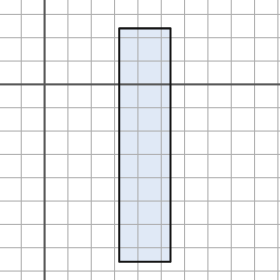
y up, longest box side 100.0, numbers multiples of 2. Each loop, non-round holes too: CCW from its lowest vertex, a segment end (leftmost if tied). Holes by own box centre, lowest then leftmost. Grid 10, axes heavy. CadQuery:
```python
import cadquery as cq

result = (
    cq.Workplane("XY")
    .moveTo(32.0, -76.0)
    .lineTo(54.0, -76.0)
    .lineTo(54.0, 24.0)
    .lineTo(32.0, 24.0)
    .close()
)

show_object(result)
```